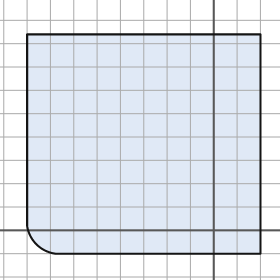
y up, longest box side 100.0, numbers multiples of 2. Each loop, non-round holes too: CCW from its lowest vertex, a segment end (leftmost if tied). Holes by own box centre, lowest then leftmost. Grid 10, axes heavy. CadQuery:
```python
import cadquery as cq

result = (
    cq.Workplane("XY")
    .moveTo(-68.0, -10.0)
    .lineTo(20.0, -10.0)
    .lineTo(20.0, 84.0)
    .lineTo(-80.0, 84.0)
    .lineTo(-80.0, 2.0)
    .threePointArc((-76.0, -6.0), (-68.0, -10.0))
    .close()
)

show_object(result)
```